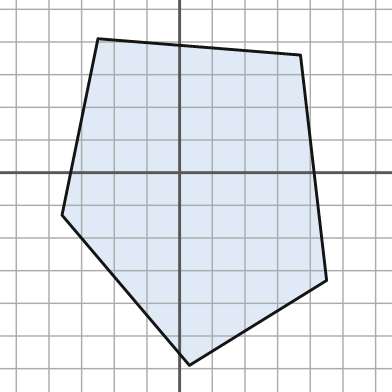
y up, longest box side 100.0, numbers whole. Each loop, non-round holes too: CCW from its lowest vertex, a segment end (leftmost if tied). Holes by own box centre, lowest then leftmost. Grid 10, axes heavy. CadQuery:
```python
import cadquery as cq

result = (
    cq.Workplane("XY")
    .moveTo(3.0, -59.0)
    .lineTo(45.0, -33.0)
    .lineTo(37.0, 36.0)
    .lineTo(-25.0, 41.0)
    .lineTo(-36.0, -13.0)
    .close()
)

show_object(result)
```